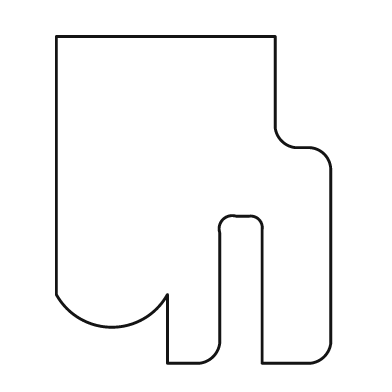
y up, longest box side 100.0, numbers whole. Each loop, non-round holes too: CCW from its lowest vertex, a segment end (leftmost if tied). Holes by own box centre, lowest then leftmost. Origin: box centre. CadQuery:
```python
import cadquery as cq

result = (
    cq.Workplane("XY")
    .moveTo(-8.0, -50.0)
    .lineTo(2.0, -50.0)
    .threePointArc((6.0, -48.0), (8.0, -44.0))
    .lineTo(8.0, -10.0)
    .threePointArc((9.0, -6.0), (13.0, -5.0))
    .lineTo(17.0, -5.0)
    .threePointArc((20.0, -6.0), (21.0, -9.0))
    .lineTo(21.0, -50.0)
    .lineTo(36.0, -50.0)
    .threePointArc((40.0, -48.0), (42.0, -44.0))
    .lineTo(42.0, 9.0)
    .threePointArc((40.0, 14.0), (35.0, 16.0))
    .lineTo(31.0, 16.0)
    .threePointArc((27.0, 18.0), (25.0, 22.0))
    .lineTo(25.0, 50.0)
    .lineTo(-42.0, 50.0)
    .lineTo(-42.0, -29.0)
    .threePointArc((-25.0, -39.0), (-8.0, -29.0))
    .close()
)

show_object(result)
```